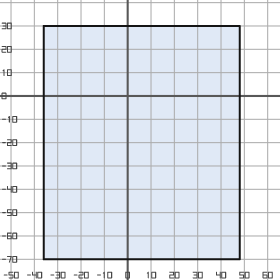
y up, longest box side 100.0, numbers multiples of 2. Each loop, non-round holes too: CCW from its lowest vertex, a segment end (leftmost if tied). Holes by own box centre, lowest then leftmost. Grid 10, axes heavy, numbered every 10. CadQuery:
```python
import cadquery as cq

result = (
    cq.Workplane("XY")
    .moveTo(-36.0, -70.0)
    .lineTo(48.0, -70.0)
    .lineTo(48.0, 30.0)
    .lineTo(-36.0, 30.0)
    .close()
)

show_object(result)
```